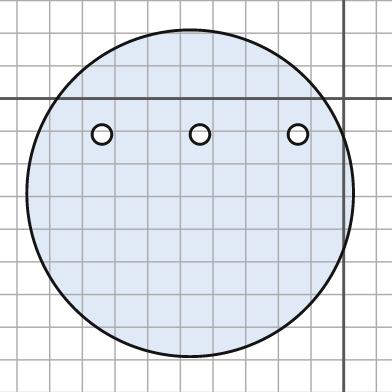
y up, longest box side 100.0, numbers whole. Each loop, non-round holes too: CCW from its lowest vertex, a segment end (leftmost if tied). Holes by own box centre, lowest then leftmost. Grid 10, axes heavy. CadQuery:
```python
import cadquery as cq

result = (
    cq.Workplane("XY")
    .moveTo(-47.0, -29.0)
    .circle(50.0)
    .moveTo(-74.0, -11.0)
    .circle(3.0)
    .moveTo(-44.0, -11.0)
    .circle(3.0)
    .moveTo(-14.0, -11.0)
    .circle(3.0)
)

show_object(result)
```